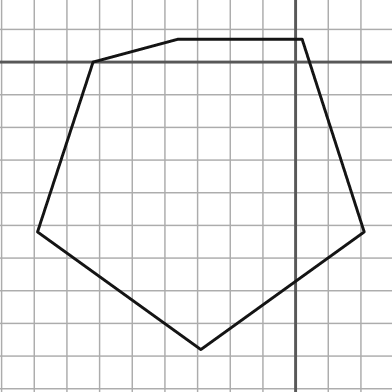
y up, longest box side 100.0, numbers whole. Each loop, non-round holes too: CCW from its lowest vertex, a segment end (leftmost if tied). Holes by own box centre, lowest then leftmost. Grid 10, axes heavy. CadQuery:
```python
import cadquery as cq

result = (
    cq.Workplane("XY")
    .moveTo(-29.0, -88.0)
    .lineTo(21.0, -52.0)
    .lineTo(2.0, 7.0)
    .lineTo(-36.0, 7.0)
    .lineTo(-62.0, 0.0)
    .lineTo(-79.0, -52.0)
    .close()
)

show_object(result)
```